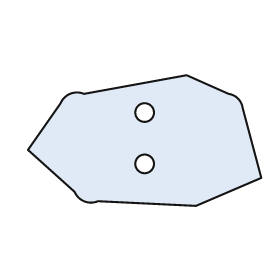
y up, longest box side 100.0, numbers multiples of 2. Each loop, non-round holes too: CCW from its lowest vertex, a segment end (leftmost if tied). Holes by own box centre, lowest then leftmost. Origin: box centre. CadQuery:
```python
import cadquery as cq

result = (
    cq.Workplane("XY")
    .moveTo(22.0, -28.0)
    .lineTo(50.0, -16.0)
    .lineTo(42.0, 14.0)
    .threePointArc((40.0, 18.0), (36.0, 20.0))
    .lineTo(18.0, 28.0)
    .lineTo(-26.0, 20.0)
    .threePointArc((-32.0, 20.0), (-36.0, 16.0))
    .lineTo(-50.0, -4.0)
    .lineTo(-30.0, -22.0)
    .threePointArc((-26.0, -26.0), (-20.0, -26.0))
    .close()
    .moveTo(0.0, -10.0)
    .circle(4.0)
    .moveTo(0.0, 12.0)
    .circle(4.0)
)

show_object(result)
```